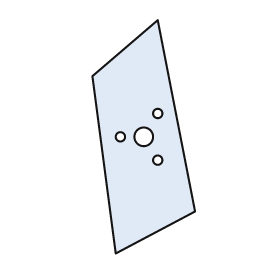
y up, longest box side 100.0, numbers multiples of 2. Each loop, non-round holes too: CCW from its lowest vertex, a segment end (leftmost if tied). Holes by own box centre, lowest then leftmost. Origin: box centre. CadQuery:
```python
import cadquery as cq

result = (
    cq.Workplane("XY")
    .moveTo(-12.0, -50.0)
    .lineTo(22.0, -32.0)
    .lineTo(6.0, 50.0)
    .lineTo(-22.0, 26.0)
    .close()
    .moveTo(6.0, -10.0)
    .circle(2.0)
    .moveTo(-10.0, 0.0)
    .circle(2.0)
    .moveTo(0.0, 0.0)
    .circle(4.0)
    .moveTo(6.0, 10.0)
    .circle(2.0)
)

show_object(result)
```